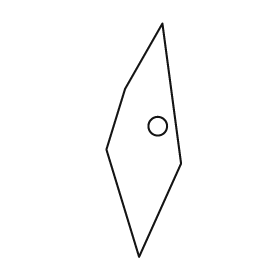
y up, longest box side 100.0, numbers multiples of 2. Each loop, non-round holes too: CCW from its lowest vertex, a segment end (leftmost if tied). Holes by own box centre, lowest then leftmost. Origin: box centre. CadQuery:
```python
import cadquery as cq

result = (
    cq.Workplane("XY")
    .moveTo(-2.0, -50.0)
    .lineTo(16.0, -10.0)
    .lineTo(8.0, 50.0)
    .lineTo(-8.0, 22.0)
    .lineTo(-16.0, -4.0)
    .close()
    .moveTo(6.0, 6.0)
    .circle(4.0)
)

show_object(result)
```